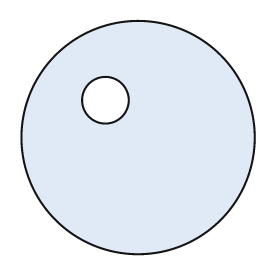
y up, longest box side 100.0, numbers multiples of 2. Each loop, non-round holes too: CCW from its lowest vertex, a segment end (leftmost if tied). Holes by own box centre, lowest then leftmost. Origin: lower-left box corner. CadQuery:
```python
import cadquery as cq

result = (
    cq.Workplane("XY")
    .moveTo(50.0, 50.0)
    .circle(50.0)
    .moveTo(36.0, 66.0)
    .circle(10.0)
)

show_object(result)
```